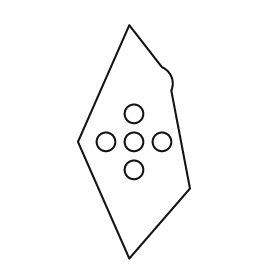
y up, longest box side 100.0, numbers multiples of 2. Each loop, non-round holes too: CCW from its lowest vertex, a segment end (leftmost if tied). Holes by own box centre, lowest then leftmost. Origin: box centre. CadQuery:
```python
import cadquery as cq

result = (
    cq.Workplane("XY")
    .moveTo(-2.0, -50.0)
    .lineTo(24.0, -20.0)
    .lineTo(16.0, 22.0)
    .threePointArc((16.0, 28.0), (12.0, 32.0))
    .lineTo(-2.0, 50.0)
    .lineTo(-24.0, 0.0)
    .close()
    .moveTo(0.0, -12.0)
    .circle(4.0)
    .moveTo(-12.0, 0.0)
    .circle(4.0)
    .moveTo(0.0, 0.0)
    .circle(4.0)
    .moveTo(12.0, 0.0)
    .circle(4.0)
    .moveTo(0.0, 12.0)
    .circle(4.0)
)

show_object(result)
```